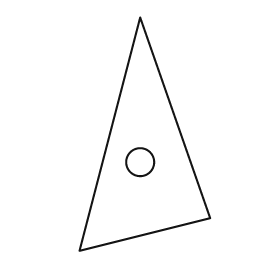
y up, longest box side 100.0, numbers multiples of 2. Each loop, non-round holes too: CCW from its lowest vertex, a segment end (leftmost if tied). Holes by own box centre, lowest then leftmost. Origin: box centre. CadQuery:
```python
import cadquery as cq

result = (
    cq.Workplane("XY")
    .moveTo(-28.0, -50.0)
    .lineTo(28.0, -36.0)
    .lineTo(-2.0, 50.0)
    .close()
    .moveTo(-2.0, -12.0)
    .circle(6.0)
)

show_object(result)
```